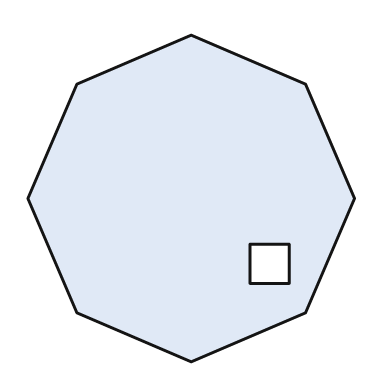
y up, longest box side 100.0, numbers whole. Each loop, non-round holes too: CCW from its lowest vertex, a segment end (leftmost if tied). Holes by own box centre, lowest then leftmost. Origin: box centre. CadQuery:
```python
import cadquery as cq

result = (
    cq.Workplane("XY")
    .moveTo(0.0, -50.0)
    .lineTo(35.0, -35.0)
    .lineTo(50.0, 0.0)
    .lineTo(35.0, 35.0)
    .lineTo(0.0, 50.0)
    .lineTo(-35.0, 35.0)
    .lineTo(-50.0, 0.0)
    .lineTo(-35.0, -35.0)
    .close()
    .moveTo(18.0, -26.0)
    .lineTo(30.0, -26.0)
    .lineTo(30.0, -14.0)
    .lineTo(18.0, -14.0)
    .close()
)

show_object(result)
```